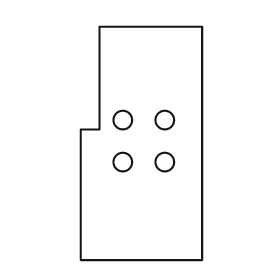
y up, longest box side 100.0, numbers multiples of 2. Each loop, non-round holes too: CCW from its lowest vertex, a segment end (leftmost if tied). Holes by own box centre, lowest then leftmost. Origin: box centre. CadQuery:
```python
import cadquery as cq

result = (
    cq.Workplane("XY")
    .moveTo(-26.0, -50.0)
    .lineTo(26.0, -50.0)
    .lineTo(26.0, 50.0)
    .lineTo(-18.0, 50.0)
    .lineTo(-18.0, 6.0)
    .lineTo(-26.0, 6.0)
    .close()
    .moveTo(-8.0, -8.0)
    .circle(4.0)
    .moveTo(10.0, -8.0)
    .circle(4.0)
    .moveTo(-8.0, 10.0)
    .circle(4.0)
    .moveTo(10.0, 10.0)
    .circle(4.0)
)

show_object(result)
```